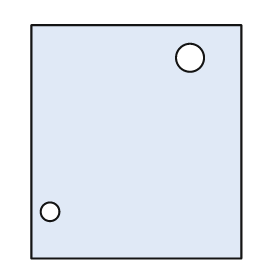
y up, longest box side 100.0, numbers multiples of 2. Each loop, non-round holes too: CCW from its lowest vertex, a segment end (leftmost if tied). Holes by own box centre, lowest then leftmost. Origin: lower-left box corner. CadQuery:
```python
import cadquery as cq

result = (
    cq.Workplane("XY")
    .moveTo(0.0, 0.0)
    .lineTo(90.0, 0.0)
    .lineTo(90.0, 100.0)
    .lineTo(0.0, 100.0)
    .close()
    .moveTo(8.0, 20.0)
    .circle(4.0)
    .moveTo(68.0, 86.0)
    .circle(6.0)
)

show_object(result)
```